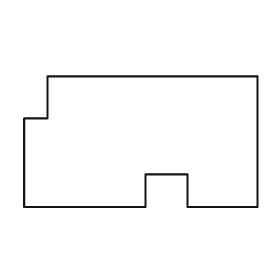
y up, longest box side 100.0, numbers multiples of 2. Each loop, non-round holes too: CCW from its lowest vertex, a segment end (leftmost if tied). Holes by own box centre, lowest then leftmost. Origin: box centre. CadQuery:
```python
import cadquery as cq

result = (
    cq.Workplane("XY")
    .moveTo(-50.0, -28.0)
    .lineTo(2.0, -28.0)
    .lineTo(2.0, -14.0)
    .lineTo(20.0, -14.0)
    .lineTo(20.0, -28.0)
    .lineTo(50.0, -28.0)
    .lineTo(50.0, 28.0)
    .lineTo(-40.0, 28.0)
    .lineTo(-40.0, 10.0)
    .lineTo(-50.0, 10.0)
    .close()
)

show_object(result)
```